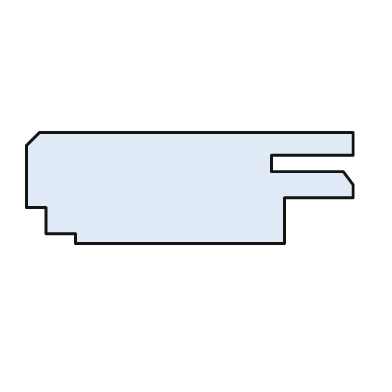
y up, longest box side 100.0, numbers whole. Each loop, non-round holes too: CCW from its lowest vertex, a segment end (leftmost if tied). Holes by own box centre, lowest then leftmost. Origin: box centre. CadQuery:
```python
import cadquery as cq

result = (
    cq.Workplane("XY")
    .moveTo(-35.0, -17.0)
    .lineTo(29.0, -17.0)
    .lineTo(29.0, -3.0)
    .lineTo(50.0, -3.0)
    .lineTo(50.0, 1.0)
    .lineTo(47.0, 5.0)
    .lineTo(25.0, 5.0)
    .lineTo(25.0, 10.0)
    .lineTo(50.0, 10.0)
    .lineTo(50.0, 17.0)
    .lineTo(-46.0, 17.0)
    .lineTo(-50.0, 13.0)
    .lineTo(-50.0, -6.0)
    .lineTo(-44.0, -6.0)
    .lineTo(-44.0, -14.0)
    .lineTo(-35.0, -14.0)
    .close()
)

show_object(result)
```